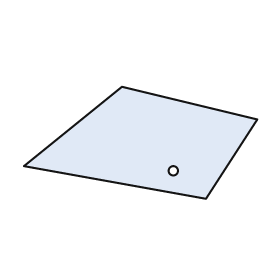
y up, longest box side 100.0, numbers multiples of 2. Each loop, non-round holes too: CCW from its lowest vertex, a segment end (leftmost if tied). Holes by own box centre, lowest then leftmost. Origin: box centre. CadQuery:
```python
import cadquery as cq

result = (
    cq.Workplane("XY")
    .moveTo(28.0, -24.0)
    .lineTo(50.0, 10.0)
    .lineTo(-8.0, 24.0)
    .lineTo(-50.0, -10.0)
    .close()
    .moveTo(14.0, -12.0)
    .circle(2.0)
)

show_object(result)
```